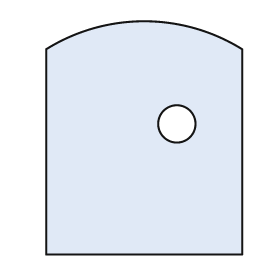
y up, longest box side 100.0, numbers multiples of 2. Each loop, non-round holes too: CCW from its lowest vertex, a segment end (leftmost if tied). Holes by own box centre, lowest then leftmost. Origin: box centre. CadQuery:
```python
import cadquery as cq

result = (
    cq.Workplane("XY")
    .moveTo(-42.0, -50.0)
    .lineTo(42.0, -50.0)
    .lineTo(42.0, 38.0)
    .threePointArc((0.0, 50.0), (-42.0, 38.0))
    .close()
    .moveTo(14.0, 6.0)
    .circle(8.0)
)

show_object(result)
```